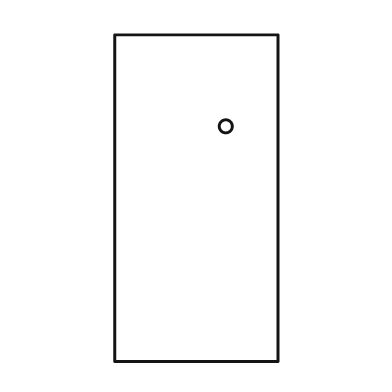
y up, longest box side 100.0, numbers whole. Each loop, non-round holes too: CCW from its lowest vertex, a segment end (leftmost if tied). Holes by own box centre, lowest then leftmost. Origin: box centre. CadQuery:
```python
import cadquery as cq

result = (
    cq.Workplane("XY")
    .moveTo(-25.0, -50.0)
    .lineTo(25.0, -50.0)
    .lineTo(25.0, 50.0)
    .lineTo(-25.0, 50.0)
    .close()
    .moveTo(9.0, 22.0)
    .circle(2.0)
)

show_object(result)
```